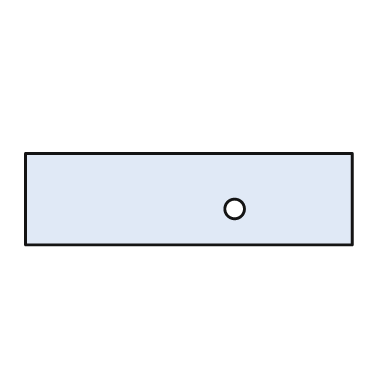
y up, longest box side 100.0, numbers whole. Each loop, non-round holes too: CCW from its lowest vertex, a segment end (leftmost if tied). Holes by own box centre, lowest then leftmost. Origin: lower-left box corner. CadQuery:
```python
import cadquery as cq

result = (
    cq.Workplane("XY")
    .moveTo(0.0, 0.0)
    .lineTo(100.0, 0.0)
    .lineTo(100.0, 28.0)
    .lineTo(0.0, 28.0)
    .close()
    .moveTo(64.0, 11.0)
    .circle(3.0)
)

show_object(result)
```